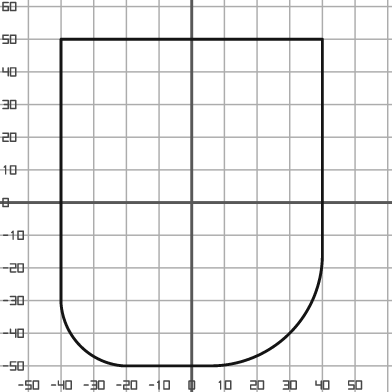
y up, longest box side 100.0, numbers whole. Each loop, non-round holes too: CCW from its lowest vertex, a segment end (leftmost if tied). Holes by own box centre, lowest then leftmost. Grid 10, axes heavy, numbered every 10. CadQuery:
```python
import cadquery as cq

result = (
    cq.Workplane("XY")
    .moveTo(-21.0, -50.0)
    .lineTo(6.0, -50.0)
    .threePointArc((30.0, -40.0), (40.0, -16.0))
    .lineTo(40.0, 50.0)
    .lineTo(-40.0, 50.0)
    .lineTo(-40.0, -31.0)
    .threePointArc((-34.0, -44.0), (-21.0, -50.0))
    .close()
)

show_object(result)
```